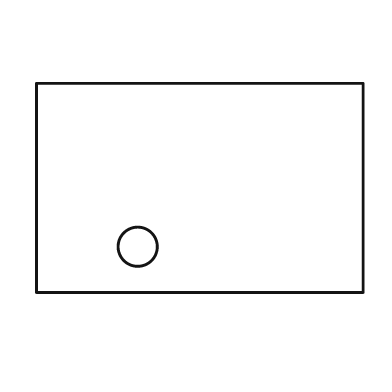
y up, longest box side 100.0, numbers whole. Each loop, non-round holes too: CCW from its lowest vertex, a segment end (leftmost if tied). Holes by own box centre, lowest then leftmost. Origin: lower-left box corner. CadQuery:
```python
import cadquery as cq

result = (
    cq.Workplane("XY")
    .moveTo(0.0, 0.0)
    .lineTo(100.0, 0.0)
    .lineTo(100.0, 64.0)
    .lineTo(0.0, 64.0)
    .close()
    .moveTo(31.0, 14.0)
    .circle(6.0)
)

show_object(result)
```